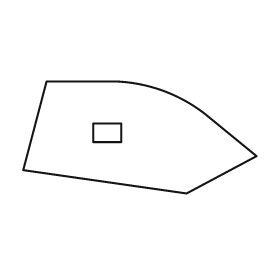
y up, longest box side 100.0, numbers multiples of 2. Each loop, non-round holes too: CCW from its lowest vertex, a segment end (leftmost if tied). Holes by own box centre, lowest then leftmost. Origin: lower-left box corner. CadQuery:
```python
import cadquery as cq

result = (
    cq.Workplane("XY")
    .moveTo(70.0, 0.0)
    .lineTo(100.0, 16.0)
    .lineTo(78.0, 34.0)
    .threePointArc((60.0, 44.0), (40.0, 48.0))
    .lineTo(10.0, 48.0)
    .lineTo(0.0, 10.0)
    .close()
    .moveTo(30.0, 22.0)
    .lineTo(42.0, 22.0)
    .lineTo(42.0, 30.0)
    .lineTo(30.0, 30.0)
    .close()
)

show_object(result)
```